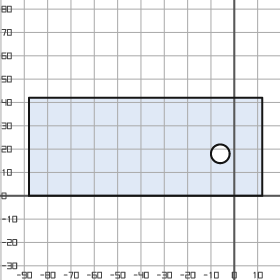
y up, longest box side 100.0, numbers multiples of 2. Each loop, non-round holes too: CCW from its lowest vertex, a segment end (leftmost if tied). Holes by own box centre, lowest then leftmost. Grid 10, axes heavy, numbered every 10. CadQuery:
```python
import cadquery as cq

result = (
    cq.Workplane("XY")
    .moveTo(-88.0, 0.0)
    .lineTo(12.0, 0.0)
    .lineTo(12.0, 42.0)
    .lineTo(-88.0, 42.0)
    .close()
    .moveTo(-6.0, 18.0)
    .circle(4.0)
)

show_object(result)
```